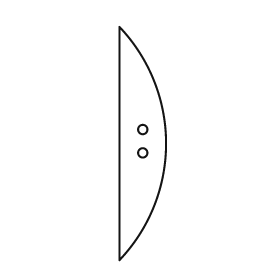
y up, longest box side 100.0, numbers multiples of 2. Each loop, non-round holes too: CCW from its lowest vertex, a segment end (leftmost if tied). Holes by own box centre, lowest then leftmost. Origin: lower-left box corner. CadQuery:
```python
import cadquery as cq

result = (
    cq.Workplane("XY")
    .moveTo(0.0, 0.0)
    .threePointArc((20.0, 50.0), (0.0, 100.0))
    .close()
    .moveTo(10.0, 46.0)
    .circle(2.0)
    .moveTo(10.0, 56.0)
    .circle(2.0)
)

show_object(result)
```